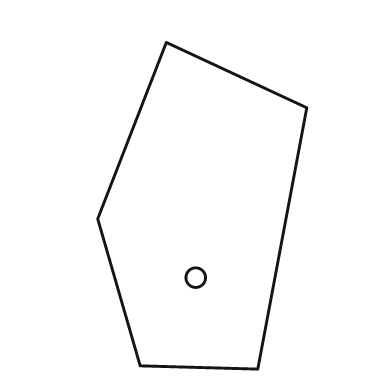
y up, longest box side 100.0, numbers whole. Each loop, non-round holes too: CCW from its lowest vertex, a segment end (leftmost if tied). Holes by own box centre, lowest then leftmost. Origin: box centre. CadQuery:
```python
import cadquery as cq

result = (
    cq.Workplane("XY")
    .moveTo(17.0, -50.0)
    .lineTo(32.0, 30.0)
    .lineTo(-11.0, 50.0)
    .lineTo(-32.0, -4.0)
    .lineTo(-19.0, -49.0)
    .close()
    .moveTo(-2.0, -22.0)
    .circle(3.0)
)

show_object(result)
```